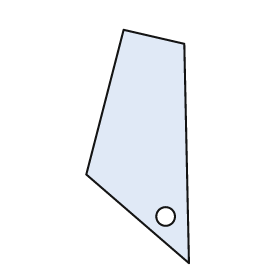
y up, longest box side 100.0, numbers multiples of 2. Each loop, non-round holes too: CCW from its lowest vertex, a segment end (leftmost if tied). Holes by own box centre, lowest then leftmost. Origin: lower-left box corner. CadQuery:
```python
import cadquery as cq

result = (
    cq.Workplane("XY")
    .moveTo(44.0, 0.0)
    .lineTo(42.0, 94.0)
    .lineTo(16.0, 100.0)
    .lineTo(0.0, 38.0)
    .close()
    .moveTo(34.0, 20.0)
    .circle(4.0)
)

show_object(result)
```